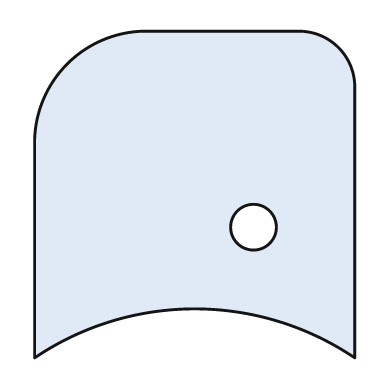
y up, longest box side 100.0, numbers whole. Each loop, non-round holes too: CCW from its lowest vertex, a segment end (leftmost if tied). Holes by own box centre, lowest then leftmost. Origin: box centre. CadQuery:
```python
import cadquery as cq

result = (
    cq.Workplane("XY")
    .moveTo(-49.0, -50.0)
    .threePointArc((0.0, -35.0), (49.0, -50.0))
    .lineTo(49.0, 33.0)
    .threePointArc((44.0, 45.0), (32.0, 50.0))
    .lineTo(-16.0, 50.0)
    .threePointArc((-39.0, 40.0), (-49.0, 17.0))
    .close()
    .moveTo(18.0, -10.0)
    .circle(7.0)
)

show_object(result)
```